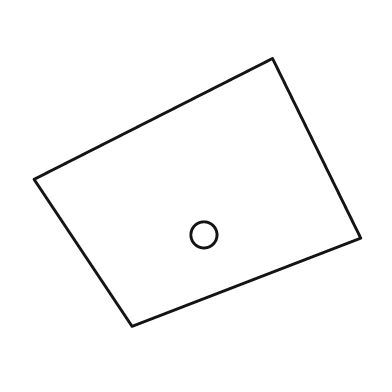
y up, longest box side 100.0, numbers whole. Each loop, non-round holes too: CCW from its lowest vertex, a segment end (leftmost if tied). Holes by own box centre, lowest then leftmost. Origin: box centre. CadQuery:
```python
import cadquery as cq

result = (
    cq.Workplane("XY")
    .moveTo(-20.0, -41.0)
    .lineTo(50.0, -14.0)
    .lineTo(23.0, 41.0)
    .lineTo(-50.0, 4.0)
    .close()
    .moveTo(2.0, -13.0)
    .circle(4.0)
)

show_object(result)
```